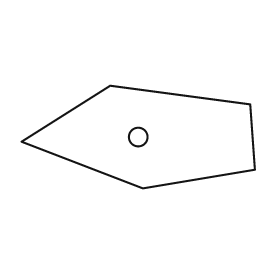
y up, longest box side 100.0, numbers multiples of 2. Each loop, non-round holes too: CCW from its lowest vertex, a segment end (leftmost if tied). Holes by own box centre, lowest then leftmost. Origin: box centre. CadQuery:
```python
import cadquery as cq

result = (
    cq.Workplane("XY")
    .moveTo(2.0, -22.0)
    .lineTo(50.0, -14.0)
    .lineTo(48.0, 14.0)
    .lineTo(-12.0, 22.0)
    .lineTo(-50.0, -2.0)
    .close()
    .moveTo(0.0, 0.0)
    .circle(4.0)
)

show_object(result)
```